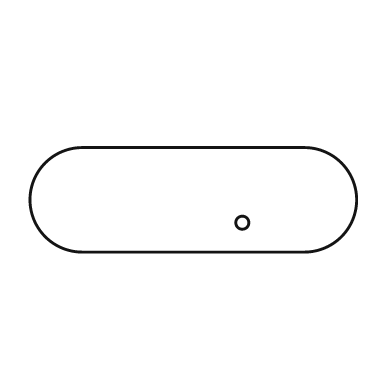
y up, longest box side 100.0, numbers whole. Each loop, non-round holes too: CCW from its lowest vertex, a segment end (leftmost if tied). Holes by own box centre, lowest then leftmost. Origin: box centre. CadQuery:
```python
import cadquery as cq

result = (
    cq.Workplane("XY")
    .moveTo(-34.0, -16.0)
    .lineTo(34.0, -16.0)
    .threePointArc((50.0, 0.0), (34.0, 16.0))
    .lineTo(-34.0, 16.0)
    .threePointArc((-50.0, 0.0), (-34.0, -16.0))
    .close()
    .moveTo(15.0, -7.0)
    .circle(2.0)
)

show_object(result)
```